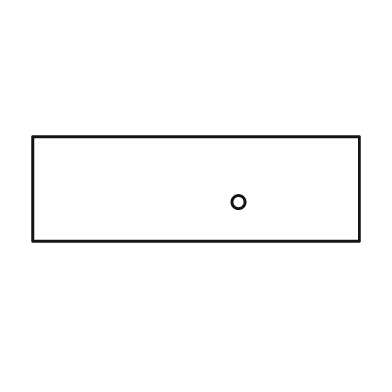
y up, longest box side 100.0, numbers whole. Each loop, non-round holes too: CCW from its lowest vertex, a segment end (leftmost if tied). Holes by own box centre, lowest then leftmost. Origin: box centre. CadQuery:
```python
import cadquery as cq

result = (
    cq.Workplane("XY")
    .moveTo(-50.0, -16.0)
    .lineTo(50.0, -16.0)
    .lineTo(50.0, 16.0)
    .lineTo(-50.0, 16.0)
    .close()
    .moveTo(13.0, -4.0)
    .circle(2.0)
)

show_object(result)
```